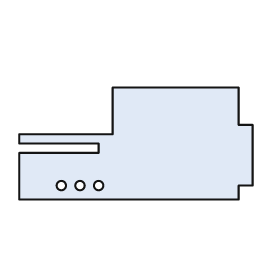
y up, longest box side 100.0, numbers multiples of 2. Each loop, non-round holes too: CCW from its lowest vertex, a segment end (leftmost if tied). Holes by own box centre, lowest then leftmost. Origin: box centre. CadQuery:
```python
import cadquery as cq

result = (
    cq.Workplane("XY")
    .moveTo(-50.0, -24.0)
    .lineTo(44.0, -24.0)
    .lineTo(44.0, -18.0)
    .lineTo(50.0, -18.0)
    .lineTo(50.0, 8.0)
    .lineTo(44.0, 8.0)
    .lineTo(44.0, 24.0)
    .lineTo(-10.0, 24.0)
    .lineTo(-10.0, 4.0)
    .lineTo(-50.0, 4.0)
    .lineTo(-50.0, 0.0)
    .lineTo(-16.0, 0.0)
    .lineTo(-16.0, -4.0)
    .lineTo(-50.0, -4.0)
    .close()
    .moveTo(-32.0, -18.0)
    .circle(2.0)
    .moveTo(-24.0, -18.0)
    .circle(2.0)
    .moveTo(-16.0, -18.0)
    .circle(2.0)
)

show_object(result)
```